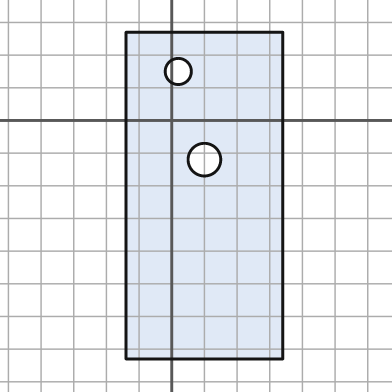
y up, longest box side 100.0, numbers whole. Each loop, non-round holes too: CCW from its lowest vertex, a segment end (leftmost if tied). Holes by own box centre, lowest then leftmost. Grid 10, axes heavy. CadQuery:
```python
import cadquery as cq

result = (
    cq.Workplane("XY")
    .moveTo(-14.0, -73.0)
    .lineTo(34.0, -73.0)
    .lineTo(34.0, 27.0)
    .lineTo(-14.0, 27.0)
    .close()
    .moveTo(10.0, -12.0)
    .circle(5.0)
    .moveTo(2.0, 15.0)
    .circle(4.0)
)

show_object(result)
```